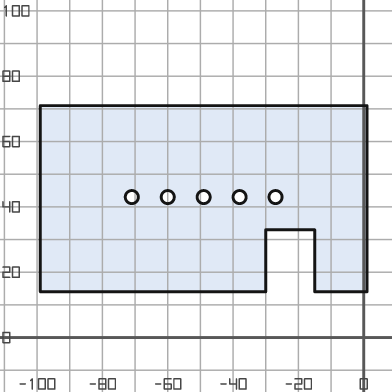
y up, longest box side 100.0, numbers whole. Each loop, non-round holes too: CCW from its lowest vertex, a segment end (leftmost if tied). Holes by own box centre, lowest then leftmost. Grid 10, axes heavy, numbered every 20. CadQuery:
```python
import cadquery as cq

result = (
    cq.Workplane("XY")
    .moveTo(-99.0, 14.0)
    .lineTo(-30.0, 14.0)
    .lineTo(-30.0, 33.0)
    .lineTo(-15.0, 33.0)
    .lineTo(-15.0, 14.0)
    .lineTo(1.0, 14.0)
    .lineTo(1.0, 71.0)
    .lineTo(-99.0, 71.0)
    .close()
    .moveTo(-71.0, 43.0)
    .circle(2.0)
    .moveTo(-60.0, 43.0)
    .circle(2.0)
    .moveTo(-49.0, 43.0)
    .circle(2.0)
    .moveTo(-38.0, 43.0)
    .circle(2.0)
    .moveTo(-27.0, 43.0)
    .circle(2.0)
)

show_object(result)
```